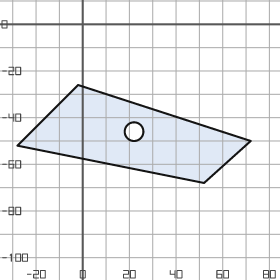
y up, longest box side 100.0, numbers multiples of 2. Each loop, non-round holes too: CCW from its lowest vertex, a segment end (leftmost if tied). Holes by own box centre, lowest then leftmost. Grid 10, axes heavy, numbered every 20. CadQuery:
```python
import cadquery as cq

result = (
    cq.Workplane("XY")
    .moveTo(52.0, -68.0)
    .lineTo(72.0, -50.0)
    .lineTo(-2.0, -26.0)
    .lineTo(-28.0, -52.0)
    .close()
    .moveTo(22.0, -46.0)
    .circle(4.0)
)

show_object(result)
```